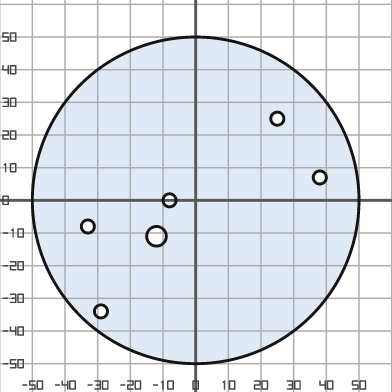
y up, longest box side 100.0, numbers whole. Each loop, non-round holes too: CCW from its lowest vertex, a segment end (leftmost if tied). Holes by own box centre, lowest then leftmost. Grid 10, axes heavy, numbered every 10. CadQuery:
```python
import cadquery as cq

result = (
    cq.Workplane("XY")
    .moveTo(0.0, 0.0)
    .circle(50.0)
    .moveTo(-29.0, -34.0)
    .circle(2.0)
    .moveTo(-12.0, -11.0)
    .circle(3.0)
    .moveTo(-33.0, -8.0)
    .circle(2.0)
    .moveTo(-8.0, 0.0)
    .circle(2.0)
    .moveTo(38.0, 7.0)
    .circle(2.0)
    .moveTo(25.0, 25.0)
    .circle(2.0)
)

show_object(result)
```